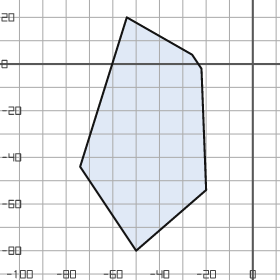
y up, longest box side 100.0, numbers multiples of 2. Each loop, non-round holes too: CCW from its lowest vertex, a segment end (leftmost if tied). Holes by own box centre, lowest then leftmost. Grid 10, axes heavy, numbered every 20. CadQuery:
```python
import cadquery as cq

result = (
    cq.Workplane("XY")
    .moveTo(-50.0, -80.0)
    .lineTo(-20.0, -54.0)
    .lineTo(-22.0, -2.0)
    .lineTo(-26.0, 4.0)
    .lineTo(-54.0, 20.0)
    .lineTo(-74.0, -44.0)
    .close()
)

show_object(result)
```